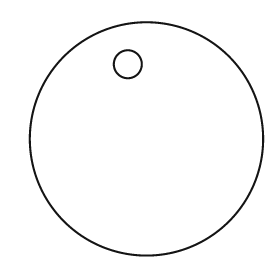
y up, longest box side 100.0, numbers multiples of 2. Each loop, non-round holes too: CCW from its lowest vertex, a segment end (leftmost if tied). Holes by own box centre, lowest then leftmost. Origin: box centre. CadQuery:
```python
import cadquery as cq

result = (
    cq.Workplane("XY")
    .moveTo(0.0, 0.0)
    .circle(50.0)
    .moveTo(-8.0, 32.0)
    .circle(6.0)
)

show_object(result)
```